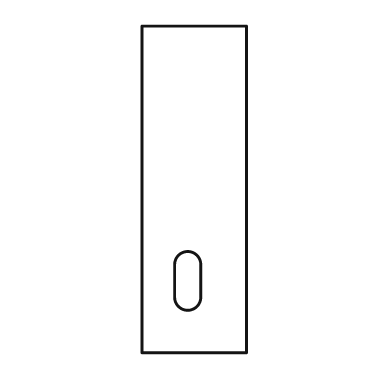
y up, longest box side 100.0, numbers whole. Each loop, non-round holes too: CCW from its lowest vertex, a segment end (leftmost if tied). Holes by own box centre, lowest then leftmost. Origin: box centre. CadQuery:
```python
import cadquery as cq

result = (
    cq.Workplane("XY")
    .moveTo(-16.0, -50.0)
    .lineTo(16.0, -50.0)
    .lineTo(16.0, 50.0)
    .lineTo(-16.0, 50.0)
    .close()
    .moveTo(-6.0, -33.0)
    .threePointArc((-2.0, -37.0), (2.0, -33.0))
    .lineTo(2.0, -23.0)
    .threePointArc((-2.0, -19.0), (-6.0, -23.0))
    .close()
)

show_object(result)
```